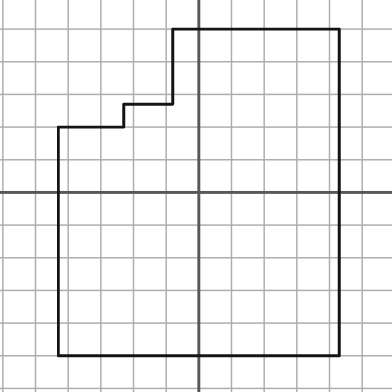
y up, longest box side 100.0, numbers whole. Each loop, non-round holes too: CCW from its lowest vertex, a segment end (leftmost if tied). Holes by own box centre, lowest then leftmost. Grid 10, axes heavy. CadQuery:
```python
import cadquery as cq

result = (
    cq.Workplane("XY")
    .moveTo(-43.0, -50.0)
    .lineTo(43.0, -50.0)
    .lineTo(43.0, 50.0)
    .lineTo(-8.0, 50.0)
    .lineTo(-8.0, 27.0)
    .lineTo(-23.0, 27.0)
    .lineTo(-23.0, 20.0)
    .lineTo(-43.0, 20.0)
    .close()
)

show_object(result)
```